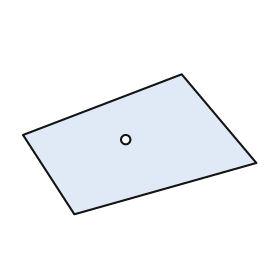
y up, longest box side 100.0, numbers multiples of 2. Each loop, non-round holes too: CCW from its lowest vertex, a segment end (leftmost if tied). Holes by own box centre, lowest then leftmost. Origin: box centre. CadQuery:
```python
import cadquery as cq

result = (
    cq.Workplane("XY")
    .moveTo(-28.0, -30.0)
    .lineTo(50.0, -8.0)
    .lineTo(18.0, 30.0)
    .lineTo(-50.0, 4.0)
    .close()
    .moveTo(-6.0, 2.0)
    .circle(2.0)
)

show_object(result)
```